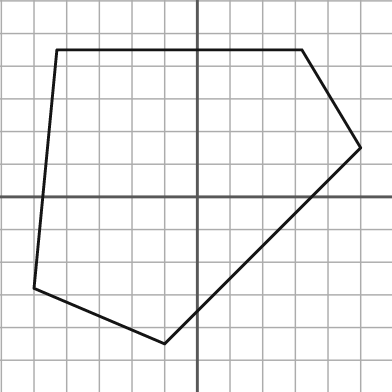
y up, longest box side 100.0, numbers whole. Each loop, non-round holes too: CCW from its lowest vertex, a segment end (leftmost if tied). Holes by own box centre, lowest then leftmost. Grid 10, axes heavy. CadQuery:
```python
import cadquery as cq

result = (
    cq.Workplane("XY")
    .moveTo(-10.0, -45.0)
    .lineTo(50.0, 15.0)
    .lineTo(32.0, 45.0)
    .lineTo(-43.0, 45.0)
    .lineTo(-50.0, -28.0)
    .close()
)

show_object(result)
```